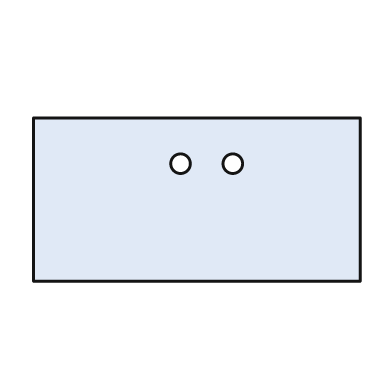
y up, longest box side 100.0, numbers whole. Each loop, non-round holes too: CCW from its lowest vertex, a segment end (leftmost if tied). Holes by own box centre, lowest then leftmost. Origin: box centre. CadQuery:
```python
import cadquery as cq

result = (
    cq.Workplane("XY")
    .moveTo(-50.0, -25.0)
    .lineTo(50.0, -25.0)
    .lineTo(50.0, 25.0)
    .lineTo(-50.0, 25.0)
    .close()
    .moveTo(-5.0, 11.0)
    .circle(3.0)
    .moveTo(11.0, 11.0)
    .circle(3.0)
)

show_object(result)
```